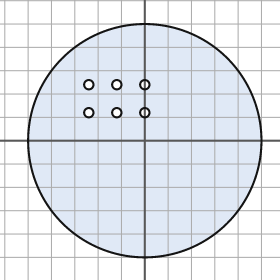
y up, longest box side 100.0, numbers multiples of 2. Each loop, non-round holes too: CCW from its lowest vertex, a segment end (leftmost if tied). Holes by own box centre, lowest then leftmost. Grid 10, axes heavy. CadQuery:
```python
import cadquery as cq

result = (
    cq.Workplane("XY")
    .moveTo(0.0, 0.0)
    .circle(50.0)
    .moveTo(-24.0, 12.0)
    .circle(2.0)
    .moveTo(-12.0, 12.0)
    .circle(2.0)
    .moveTo(0.0, 12.0)
    .circle(2.0)
    .moveTo(-24.0, 24.0)
    .circle(2.0)
    .moveTo(-12.0, 24.0)
    .circle(2.0)
    .moveTo(0.0, 24.0)
    .circle(2.0)
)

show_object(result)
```